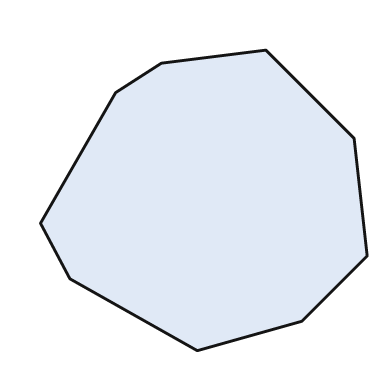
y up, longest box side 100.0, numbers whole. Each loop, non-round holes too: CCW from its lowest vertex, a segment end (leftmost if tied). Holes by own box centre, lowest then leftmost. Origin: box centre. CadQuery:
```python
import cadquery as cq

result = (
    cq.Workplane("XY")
    .moveTo(-2.0, -46.0)
    .lineTo(30.0, -37.0)
    .lineTo(50.0, -17.0)
    .lineTo(46.0, 19.0)
    .lineTo(19.0, 46.0)
    .lineTo(-13.0, 42.0)
    .lineTo(-27.0, 33.0)
    .lineTo(-50.0, -7.0)
    .lineTo(-41.0, -24.0)
    .close()
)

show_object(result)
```